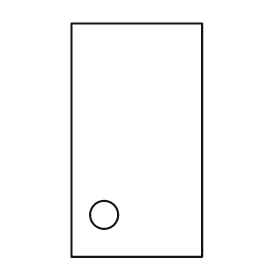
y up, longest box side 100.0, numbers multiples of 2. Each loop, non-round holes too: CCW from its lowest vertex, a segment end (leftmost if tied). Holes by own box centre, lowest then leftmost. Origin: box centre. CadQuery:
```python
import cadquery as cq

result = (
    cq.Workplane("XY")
    .moveTo(-28.0, -50.0)
    .lineTo(28.0, -50.0)
    .lineTo(28.0, 50.0)
    .lineTo(-28.0, 50.0)
    .close()
    .moveTo(-14.0, -32.0)
    .circle(6.0)
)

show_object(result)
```